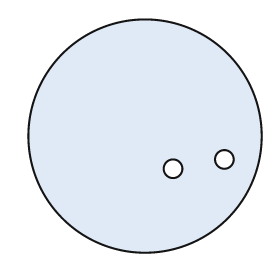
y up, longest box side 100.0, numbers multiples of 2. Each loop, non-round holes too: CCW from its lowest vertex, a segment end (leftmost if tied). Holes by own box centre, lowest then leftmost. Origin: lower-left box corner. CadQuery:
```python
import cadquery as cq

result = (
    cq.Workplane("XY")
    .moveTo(50.0, 50.0)
    .circle(50.0)
    .moveTo(62.0, 36.0)
    .circle(4.0)
    .moveTo(84.0, 40.0)
    .circle(4.0)
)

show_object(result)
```